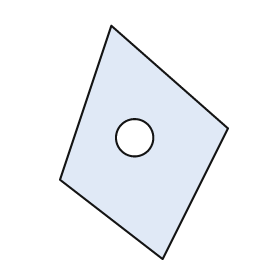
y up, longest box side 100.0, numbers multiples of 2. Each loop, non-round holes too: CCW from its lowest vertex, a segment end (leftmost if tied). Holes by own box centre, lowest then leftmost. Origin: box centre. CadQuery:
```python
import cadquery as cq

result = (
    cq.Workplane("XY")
    .moveTo(8.0, -50.0)
    .lineTo(36.0, 6.0)
    .lineTo(-14.0, 50.0)
    .lineTo(-36.0, -16.0)
    .close()
    .moveTo(-4.0, 2.0)
    .circle(8.0)
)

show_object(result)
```